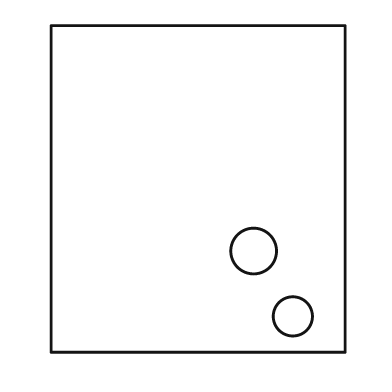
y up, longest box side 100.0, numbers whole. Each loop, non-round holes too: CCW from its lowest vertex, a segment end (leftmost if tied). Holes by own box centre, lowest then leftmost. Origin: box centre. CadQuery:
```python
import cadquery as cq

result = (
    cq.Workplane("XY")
    .moveTo(-45.0, -50.0)
    .lineTo(45.0, -50.0)
    .lineTo(45.0, 50.0)
    .lineTo(-45.0, 50.0)
    .close()
    .moveTo(29.0, -39.0)
    .circle(6.0)
    .moveTo(17.0, -19.0)
    .circle(7.0)
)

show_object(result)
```